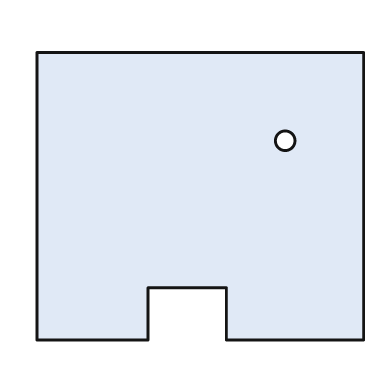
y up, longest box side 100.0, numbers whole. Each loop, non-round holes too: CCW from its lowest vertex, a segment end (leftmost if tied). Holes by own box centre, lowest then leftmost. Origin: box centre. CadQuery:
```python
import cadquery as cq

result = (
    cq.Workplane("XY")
    .moveTo(-50.0, -44.0)
    .lineTo(-16.0, -44.0)
    .lineTo(-16.0, -28.0)
    .lineTo(8.0, -28.0)
    .lineTo(8.0, -44.0)
    .lineTo(50.0, -44.0)
    .lineTo(50.0, 44.0)
    .lineTo(-50.0, 44.0)
    .close()
    .moveTo(26.0, 17.0)
    .circle(3.0)
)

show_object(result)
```